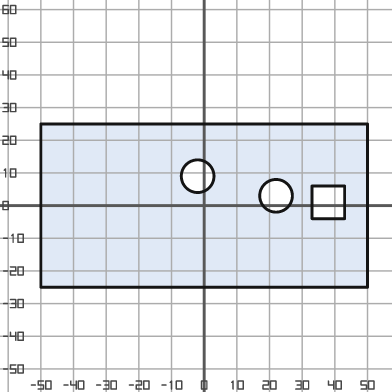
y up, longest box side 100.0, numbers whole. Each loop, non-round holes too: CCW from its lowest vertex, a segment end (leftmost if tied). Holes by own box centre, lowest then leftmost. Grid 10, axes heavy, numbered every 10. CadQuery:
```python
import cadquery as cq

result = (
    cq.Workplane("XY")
    .moveTo(-50.0, -25.0)
    .lineTo(50.0, -25.0)
    .lineTo(50.0, 25.0)
    .lineTo(-50.0, 25.0)
    .close()
    .moveTo(33.0, -4.0)
    .lineTo(43.0, -4.0)
    .lineTo(43.0, 6.0)
    .lineTo(33.0, 6.0)
    .close()
    .moveTo(22.0, 3.0)
    .circle(5.0)
    .moveTo(-2.0, 9.0)
    .circle(5.0)
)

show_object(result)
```